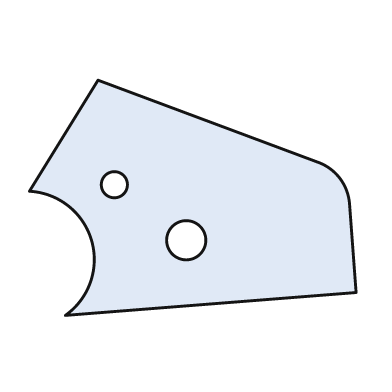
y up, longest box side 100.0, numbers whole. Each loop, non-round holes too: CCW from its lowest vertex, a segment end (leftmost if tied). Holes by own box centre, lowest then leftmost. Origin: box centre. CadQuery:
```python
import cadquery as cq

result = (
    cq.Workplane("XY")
    .moveTo(-39.0, -36.0)
    .lineTo(50.0, -29.0)
    .lineTo(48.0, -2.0)
    .threePointArc((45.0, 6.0), (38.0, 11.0))
    .lineTo(-29.0, 36.0)
    .lineTo(-50.0, 2.0)
    .threePointArc((-31.0, -13.0), (-39.0, -36.0))
    .close()
    .moveTo(-2.0, -13.0)
    .circle(6.0)
    .moveTo(-24.0, 4.0)
    .circle(4.0)
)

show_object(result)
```